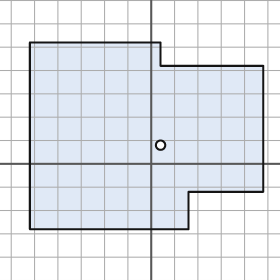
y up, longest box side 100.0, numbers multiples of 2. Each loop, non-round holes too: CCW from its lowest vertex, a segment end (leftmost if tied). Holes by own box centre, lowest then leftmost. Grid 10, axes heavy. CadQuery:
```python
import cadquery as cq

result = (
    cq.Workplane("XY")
    .moveTo(-52.0, -28.0)
    .lineTo(16.0, -28.0)
    .lineTo(16.0, -12.0)
    .lineTo(48.0, -12.0)
    .lineTo(48.0, 42.0)
    .lineTo(4.0, 42.0)
    .lineTo(4.0, 52.0)
    .lineTo(-52.0, 52.0)
    .close()
    .moveTo(4.0, 8.0)
    .circle(2.0)
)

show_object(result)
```